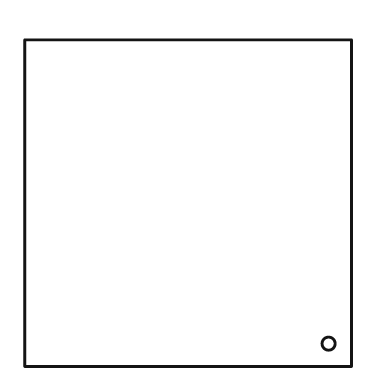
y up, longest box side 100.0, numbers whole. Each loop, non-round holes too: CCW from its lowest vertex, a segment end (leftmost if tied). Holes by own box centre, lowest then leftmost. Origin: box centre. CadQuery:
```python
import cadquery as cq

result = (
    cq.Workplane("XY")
    .moveTo(-50.0, -50.0)
    .lineTo(50.0, -50.0)
    .lineTo(50.0, 50.0)
    .lineTo(-50.0, 50.0)
    .close()
    .moveTo(43.0, -43.0)
    .circle(2.0)
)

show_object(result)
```